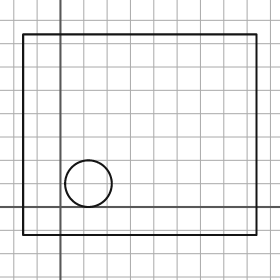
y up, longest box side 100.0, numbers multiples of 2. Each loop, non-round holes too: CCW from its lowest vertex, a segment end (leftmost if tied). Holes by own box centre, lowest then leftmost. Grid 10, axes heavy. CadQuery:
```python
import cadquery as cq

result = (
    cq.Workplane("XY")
    .moveTo(-16.0, -12.0)
    .lineTo(84.0, -12.0)
    .lineTo(84.0, 74.0)
    .lineTo(-16.0, 74.0)
    .close()
    .moveTo(12.0, 10.0)
    .circle(10.0)
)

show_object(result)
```